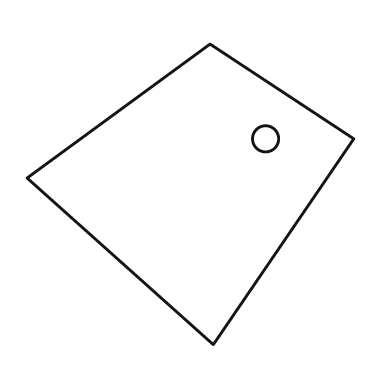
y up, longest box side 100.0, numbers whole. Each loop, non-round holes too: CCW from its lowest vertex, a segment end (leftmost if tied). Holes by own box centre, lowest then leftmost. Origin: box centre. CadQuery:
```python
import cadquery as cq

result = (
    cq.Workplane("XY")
    .moveTo(7.0, -46.0)
    .lineTo(50.0, 17.0)
    .lineTo(6.0, 46.0)
    .lineTo(-50.0, 5.0)
    .close()
    .moveTo(23.0, 17.0)
    .circle(4.0)
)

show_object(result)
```